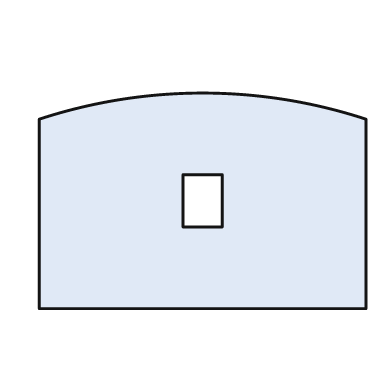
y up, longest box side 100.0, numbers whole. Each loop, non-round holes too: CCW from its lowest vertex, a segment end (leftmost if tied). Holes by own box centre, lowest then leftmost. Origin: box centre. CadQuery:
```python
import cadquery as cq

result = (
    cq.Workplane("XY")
    .moveTo(-50.0, -33.0)
    .lineTo(50.0, -33.0)
    .lineTo(50.0, 25.0)
    .threePointArc((0.0, 33.0), (-50.0, 25.0))
    .close()
    .moveTo(-6.0, -8.0)
    .lineTo(6.0, -8.0)
    .lineTo(6.0, 8.0)
    .lineTo(-6.0, 8.0)
    .close()
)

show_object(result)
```